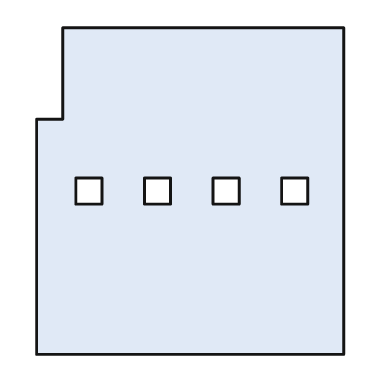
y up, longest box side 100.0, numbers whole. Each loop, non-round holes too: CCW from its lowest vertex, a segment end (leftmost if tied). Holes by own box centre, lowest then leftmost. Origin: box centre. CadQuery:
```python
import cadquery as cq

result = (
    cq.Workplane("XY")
    .moveTo(-47.0, -50.0)
    .lineTo(47.0, -50.0)
    .lineTo(47.0, 50.0)
    .lineTo(-39.0, 50.0)
    .lineTo(-39.0, 22.0)
    .lineTo(-47.0, 22.0)
    .close()
    .moveTo(-35.0, -4.0)
    .lineTo(-27.0, -4.0)
    .lineTo(-27.0, 4.0)
    .lineTo(-35.0, 4.0)
    .close()
    .moveTo(-14.0, -4.0)
    .lineTo(-6.0, -4.0)
    .lineTo(-6.0, 4.0)
    .lineTo(-14.0, 4.0)
    .close()
    .moveTo(7.0, -4.0)
    .lineTo(15.0, -4.0)
    .lineTo(15.0, 4.0)
    .lineTo(7.0, 4.0)
    .close()
    .moveTo(28.0, -4.0)
    .lineTo(36.0, -4.0)
    .lineTo(36.0, 4.0)
    .lineTo(28.0, 4.0)
    .close()
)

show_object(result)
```